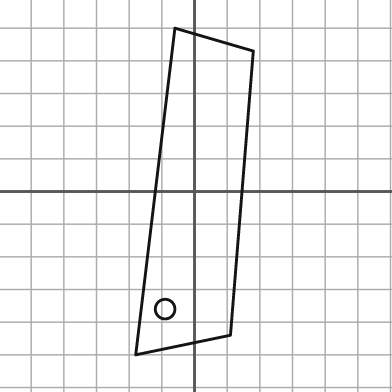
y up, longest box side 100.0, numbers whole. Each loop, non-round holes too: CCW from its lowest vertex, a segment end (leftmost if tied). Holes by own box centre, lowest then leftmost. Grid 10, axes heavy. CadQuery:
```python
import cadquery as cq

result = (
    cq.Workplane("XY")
    .moveTo(-18.0, -50.0)
    .lineTo(11.0, -44.0)
    .lineTo(18.0, 43.0)
    .lineTo(-6.0, 50.0)
    .close()
    .moveTo(-9.0, -36.0)
    .circle(3.0)
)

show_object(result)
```